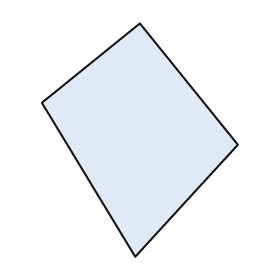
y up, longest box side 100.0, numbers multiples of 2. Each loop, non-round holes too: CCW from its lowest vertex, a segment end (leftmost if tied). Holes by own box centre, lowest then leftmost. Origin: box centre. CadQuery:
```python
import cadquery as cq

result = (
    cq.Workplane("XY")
    .moveTo(-2.0, -50.0)
    .lineTo(42.0, -2.0)
    .lineTo(0.0, 50.0)
    .lineTo(-42.0, 16.0)
    .close()
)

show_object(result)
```